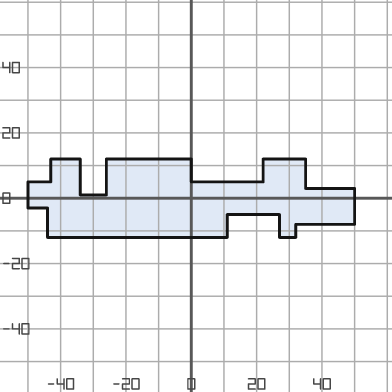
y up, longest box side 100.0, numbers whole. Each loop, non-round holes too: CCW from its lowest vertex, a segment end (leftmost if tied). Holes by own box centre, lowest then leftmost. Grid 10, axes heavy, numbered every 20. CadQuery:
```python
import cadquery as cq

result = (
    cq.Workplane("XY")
    .moveTo(-44.0, -12.0)
    .lineTo(11.0, -12.0)
    .lineTo(11.0, -5.0)
    .lineTo(27.0, -5.0)
    .lineTo(27.0, -12.0)
    .lineTo(32.0, -12.0)
    .lineTo(32.0, -8.0)
    .lineTo(50.0, -8.0)
    .lineTo(50.0, 3.0)
    .lineTo(35.0, 3.0)
    .lineTo(35.0, 12.0)
    .lineTo(22.0, 12.0)
    .lineTo(22.0, 5.0)
    .lineTo(0.0, 5.0)
    .lineTo(0.0, 12.0)
    .lineTo(-26.0, 12.0)
    .lineTo(-26.0, 1.0)
    .lineTo(-34.0, 1.0)
    .lineTo(-34.0, 12.0)
    .lineTo(-43.0, 12.0)
    .lineTo(-43.0, 5.0)
    .lineTo(-50.0, 5.0)
    .lineTo(-50.0, -3.0)
    .lineTo(-44.0, -3.0)
    .close()
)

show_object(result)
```